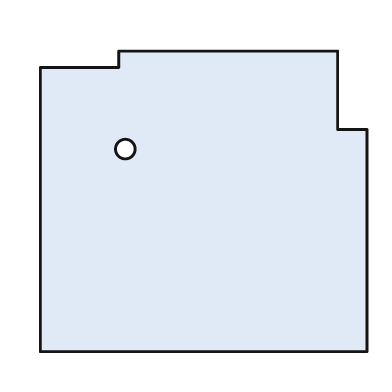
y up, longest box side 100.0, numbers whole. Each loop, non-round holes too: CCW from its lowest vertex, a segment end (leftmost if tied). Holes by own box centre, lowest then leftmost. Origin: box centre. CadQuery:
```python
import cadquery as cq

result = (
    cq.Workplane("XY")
    .moveTo(-50.0, -46.0)
    .lineTo(50.0, -46.0)
    .lineTo(50.0, 22.0)
    .lineTo(41.0, 22.0)
    .lineTo(41.0, 46.0)
    .lineTo(-26.0, 46.0)
    .lineTo(-26.0, 41.0)
    .lineTo(-50.0, 41.0)
    .close()
    .moveTo(-24.0, 16.0)
    .circle(3.0)
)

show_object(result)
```